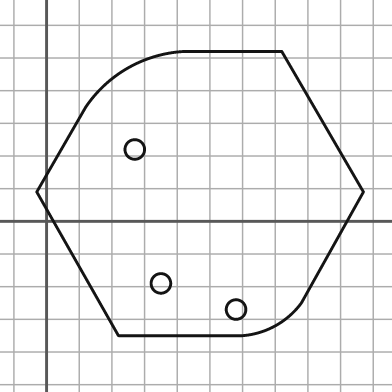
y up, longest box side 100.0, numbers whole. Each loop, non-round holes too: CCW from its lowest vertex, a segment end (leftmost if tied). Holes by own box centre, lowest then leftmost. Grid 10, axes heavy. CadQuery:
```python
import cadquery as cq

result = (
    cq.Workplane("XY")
    .moveTo(22.0, -35.0)
    .lineTo(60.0, -35.0)
    .threePointArc((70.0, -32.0), (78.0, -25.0))
    .lineTo(97.0, 9.0)
    .lineTo(72.0, 52.0)
    .lineTo(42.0, 52.0)
    .threePointArc((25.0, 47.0), (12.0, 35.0))
    .lineTo(-3.0, 9.0)
    .close()
    .moveTo(58.0, -27.0)
    .circle(3.0)
    .moveTo(35.0, -19.0)
    .circle(3.0)
    .moveTo(27.0, 22.0)
    .circle(3.0)
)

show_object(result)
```